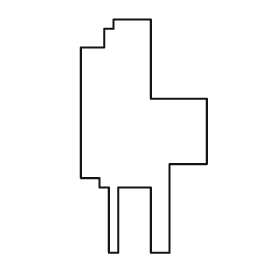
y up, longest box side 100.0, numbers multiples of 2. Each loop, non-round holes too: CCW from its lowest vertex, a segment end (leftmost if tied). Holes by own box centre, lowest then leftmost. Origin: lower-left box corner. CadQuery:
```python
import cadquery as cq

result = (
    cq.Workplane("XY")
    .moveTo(12.0, 0.0)
    .lineTo(16.0, 0.0)
    .lineTo(16.0, 28.0)
    .lineTo(30.0, 28.0)
    .lineTo(30.0, 0.0)
    .lineTo(38.0, 0.0)
    .lineTo(38.0, 38.0)
    .lineTo(54.0, 38.0)
    .lineTo(54.0, 66.0)
    .lineTo(30.0, 66.0)
    .lineTo(30.0, 100.0)
    .lineTo(14.0, 100.0)
    .lineTo(14.0, 96.0)
    .lineTo(10.0, 96.0)
    .lineTo(10.0, 88.0)
    .lineTo(0.0, 88.0)
    .lineTo(0.0, 32.0)
    .lineTo(8.0, 32.0)
    .lineTo(8.0, 28.0)
    .lineTo(12.0, 28.0)
    .close()
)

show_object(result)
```